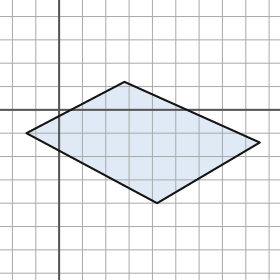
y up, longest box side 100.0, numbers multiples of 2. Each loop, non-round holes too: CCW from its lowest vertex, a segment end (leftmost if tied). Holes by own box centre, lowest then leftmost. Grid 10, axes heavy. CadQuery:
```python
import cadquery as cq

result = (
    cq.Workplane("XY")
    .moveTo(42.0, -40.0)
    .lineTo(86.0, -14.0)
    .lineTo(28.0, 12.0)
    .lineTo(-14.0, -10.0)
    .close()
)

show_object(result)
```